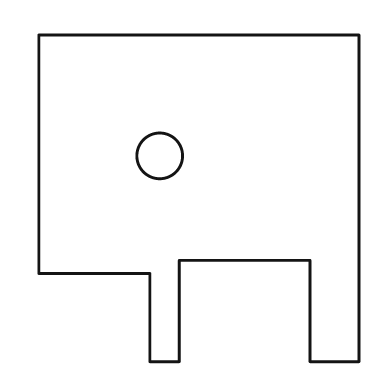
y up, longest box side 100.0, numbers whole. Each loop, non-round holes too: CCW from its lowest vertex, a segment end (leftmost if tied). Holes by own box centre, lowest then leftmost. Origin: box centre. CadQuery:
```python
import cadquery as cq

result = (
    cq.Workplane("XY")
    .moveTo(-15.0, -50.0)
    .lineTo(-6.0, -50.0)
    .lineTo(-6.0, -19.0)
    .lineTo(34.0, -19.0)
    .lineTo(34.0, -50.0)
    .lineTo(49.0, -50.0)
    .lineTo(49.0, 50.0)
    .lineTo(-49.0, 50.0)
    .lineTo(-49.0, -23.0)
    .lineTo(-15.0, -23.0)
    .close()
    .moveTo(-12.0, 13.0)
    .circle(7.0)
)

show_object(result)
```